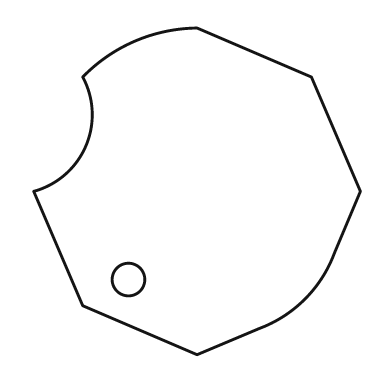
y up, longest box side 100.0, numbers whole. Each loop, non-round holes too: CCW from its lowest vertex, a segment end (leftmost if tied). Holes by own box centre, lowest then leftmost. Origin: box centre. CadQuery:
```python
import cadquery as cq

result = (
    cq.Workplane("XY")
    .moveTo(0.0, -50.0)
    .lineTo(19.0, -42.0)
    .threePointArc((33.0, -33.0), (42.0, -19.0))
    .lineTo(50.0, 0.0)
    .lineTo(35.0, 35.0)
    .lineTo(0.0, 50.0)
    .threePointArc((-19.0, 46.0), (-35.0, 35.0))
    .threePointArc((-34.0, 14.0), (-50.0, 0.0))
    .lineTo(-35.0, -35.0)
    .close()
    .moveTo(-21.0, -27.0)
    .circle(5.0)
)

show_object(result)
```